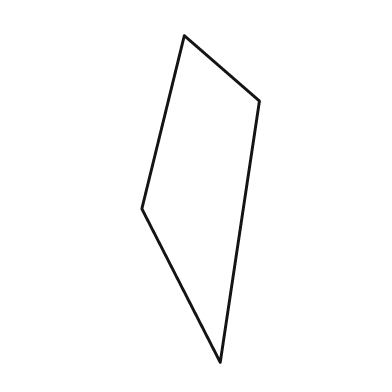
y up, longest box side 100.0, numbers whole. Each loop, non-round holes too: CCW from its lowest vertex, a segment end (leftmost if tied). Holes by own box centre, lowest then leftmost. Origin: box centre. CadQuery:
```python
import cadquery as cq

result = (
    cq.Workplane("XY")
    .moveTo(6.0, -50.0)
    .lineTo(18.0, 30.0)
    .lineTo(-5.0, 50.0)
    .lineTo(-18.0, -3.0)
    .close()
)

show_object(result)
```